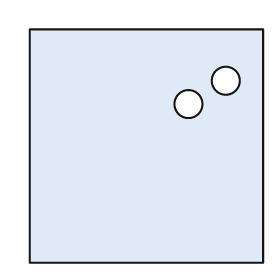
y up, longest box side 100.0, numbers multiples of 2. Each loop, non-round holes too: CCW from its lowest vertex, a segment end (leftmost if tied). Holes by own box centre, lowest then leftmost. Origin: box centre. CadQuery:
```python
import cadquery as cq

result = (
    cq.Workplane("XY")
    .moveTo(-50.0, -50.0)
    .lineTo(50.0, -50.0)
    .lineTo(50.0, 50.0)
    .lineTo(-50.0, 50.0)
    .close()
    .moveTo(18.0, 18.0)
    .circle(6.0)
    .moveTo(34.0, 28.0)
    .circle(6.0)
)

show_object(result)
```